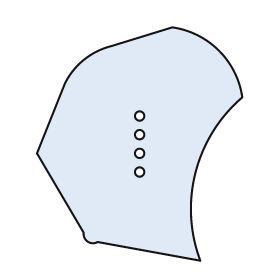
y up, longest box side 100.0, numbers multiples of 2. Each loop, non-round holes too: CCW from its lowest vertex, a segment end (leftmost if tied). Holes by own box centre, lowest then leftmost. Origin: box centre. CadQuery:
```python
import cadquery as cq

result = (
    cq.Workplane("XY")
    .moveTo(26.0, -50.0)
    .threePointArc((24.0, -12.0), (44.0, 20.0))
    .threePointArc((34.0, 40.0), (14.0, 50.0))
    .lineTo(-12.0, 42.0)
    .threePointArc((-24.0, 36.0), (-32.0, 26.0))
    .lineTo(-44.0, -4.0)
    .lineTo(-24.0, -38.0)
    .threePointArc((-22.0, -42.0), (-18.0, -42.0))
    .close()
    .moveTo(0.0, -12.0)
    .circle(2.0)
    .moveTo(0.0, -4.0)
    .circle(2.0)
    .moveTo(0.0, 4.0)
    .circle(2.0)
    .moveTo(0.0, 12.0)
    .circle(2.0)
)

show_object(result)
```